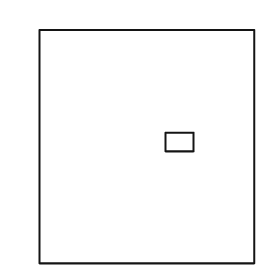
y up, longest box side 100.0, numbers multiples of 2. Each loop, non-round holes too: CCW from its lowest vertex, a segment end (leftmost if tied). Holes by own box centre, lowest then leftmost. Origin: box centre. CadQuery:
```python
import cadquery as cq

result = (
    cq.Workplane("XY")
    .moveTo(-46.0, -50.0)
    .lineTo(46.0, -50.0)
    .lineTo(46.0, 50.0)
    .lineTo(-46.0, 50.0)
    .close()
    .moveTo(8.0, -2.0)
    .lineTo(20.0, -2.0)
    .lineTo(20.0, 6.0)
    .lineTo(8.0, 6.0)
    .close()
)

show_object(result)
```